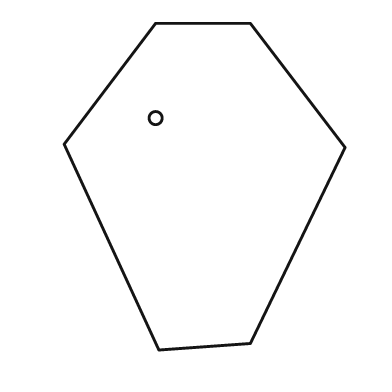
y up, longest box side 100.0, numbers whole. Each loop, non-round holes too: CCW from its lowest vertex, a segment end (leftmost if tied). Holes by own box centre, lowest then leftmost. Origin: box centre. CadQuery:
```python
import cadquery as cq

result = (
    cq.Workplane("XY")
    .moveTo(-14.0, -50.0)
    .lineTo(14.0, -48.0)
    .lineTo(43.0, 12.0)
    .lineTo(14.0, 50.0)
    .lineTo(-15.0, 50.0)
    .lineTo(-43.0, 13.0)
    .close()
    .moveTo(-15.0, 21.0)
    .circle(2.0)
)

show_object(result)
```